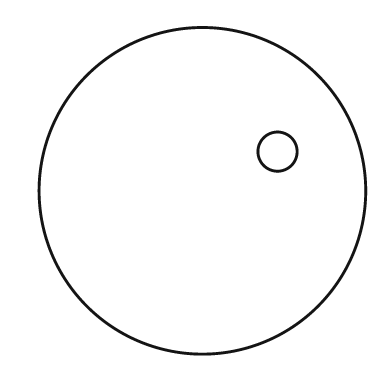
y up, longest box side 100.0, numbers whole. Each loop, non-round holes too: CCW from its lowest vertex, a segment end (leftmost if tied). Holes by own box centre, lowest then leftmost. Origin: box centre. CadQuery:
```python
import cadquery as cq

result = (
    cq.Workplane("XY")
    .moveTo(0.0, 0.0)
    .circle(50.0)
    .moveTo(23.0, 12.0)
    .circle(6.0)
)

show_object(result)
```